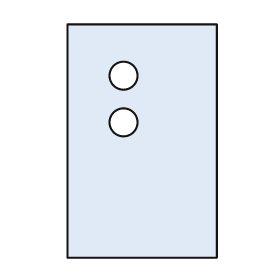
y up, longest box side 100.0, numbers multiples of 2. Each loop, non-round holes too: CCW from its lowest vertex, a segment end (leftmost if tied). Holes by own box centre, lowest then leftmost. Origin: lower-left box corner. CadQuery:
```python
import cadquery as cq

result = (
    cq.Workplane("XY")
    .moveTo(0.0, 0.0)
    .lineTo(64.0, 0.0)
    .lineTo(64.0, 100.0)
    .lineTo(0.0, 100.0)
    .close()
    .moveTo(24.0, 58.0)
    .circle(6.0)
    .moveTo(24.0, 78.0)
    .circle(6.0)
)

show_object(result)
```